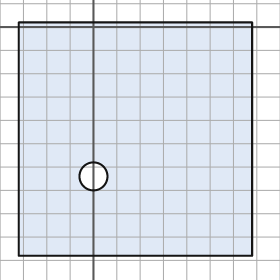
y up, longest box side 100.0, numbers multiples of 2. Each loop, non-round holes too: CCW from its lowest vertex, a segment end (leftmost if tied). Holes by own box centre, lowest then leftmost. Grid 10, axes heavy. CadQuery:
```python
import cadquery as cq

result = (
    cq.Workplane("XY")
    .moveTo(-32.0, -98.0)
    .lineTo(68.0, -98.0)
    .lineTo(68.0, 2.0)
    .lineTo(-32.0, 2.0)
    .close()
    .moveTo(0.0, -64.0)
    .circle(6.0)
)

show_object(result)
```